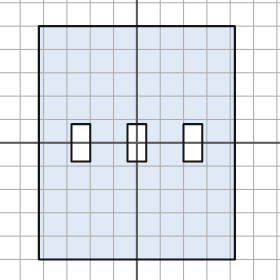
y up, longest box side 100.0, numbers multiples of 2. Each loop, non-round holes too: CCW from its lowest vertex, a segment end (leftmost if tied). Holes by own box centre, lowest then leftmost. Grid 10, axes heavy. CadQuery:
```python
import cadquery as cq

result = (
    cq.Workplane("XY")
    .moveTo(-42.0, -50.0)
    .lineTo(42.0, -50.0)
    .lineTo(42.0, 50.0)
    .lineTo(-42.0, 50.0)
    .close()
    .moveTo(-28.0, -8.0)
    .lineTo(-20.0, -8.0)
    .lineTo(-20.0, 8.0)
    .lineTo(-28.0, 8.0)
    .close()
    .moveTo(-4.0, -8.0)
    .lineTo(4.0, -8.0)
    .lineTo(4.0, 8.0)
    .lineTo(-4.0, 8.0)
    .close()
    .moveTo(20.0, -8.0)
    .lineTo(28.0, -8.0)
    .lineTo(28.0, 8.0)
    .lineTo(20.0, 8.0)
    .close()
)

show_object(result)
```